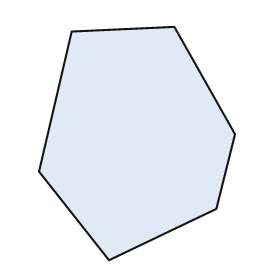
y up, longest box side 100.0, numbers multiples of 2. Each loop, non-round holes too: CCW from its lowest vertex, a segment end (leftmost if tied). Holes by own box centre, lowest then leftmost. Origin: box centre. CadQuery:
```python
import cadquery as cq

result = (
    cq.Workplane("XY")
    .moveTo(-12.0, -50.0)
    .lineTo(34.0, -28.0)
    .lineTo(42.0, 4.0)
    .lineTo(16.0, 50.0)
    .lineTo(-28.0, 48.0)
    .lineTo(-42.0, -12.0)
    .close()
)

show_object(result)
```